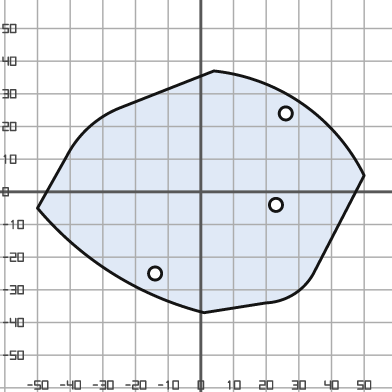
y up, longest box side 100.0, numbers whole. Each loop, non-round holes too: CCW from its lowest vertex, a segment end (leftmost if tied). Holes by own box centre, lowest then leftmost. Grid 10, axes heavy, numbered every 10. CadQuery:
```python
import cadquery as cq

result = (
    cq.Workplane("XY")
    .moveTo(1.0, -37.0)
    .lineTo(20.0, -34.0)
    .threePointArc((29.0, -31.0), (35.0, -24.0))
    .lineTo(50.0, 5.0)
    .threePointArc((31.0, 27.0), (4.0, 37.0))
    .lineTo(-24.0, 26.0)
    .threePointArc((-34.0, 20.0), (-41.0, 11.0))
    .lineTo(-50.0, -5.0)
    .threePointArc((-27.0, -25.0), (1.0, -37.0))
    .close()
    .moveTo(-14.0, -25.0)
    .circle(2.0)
    .moveTo(23.0, -4.0)
    .circle(2.0)
    .moveTo(26.0, 24.0)
    .circle(2.0)
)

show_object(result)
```